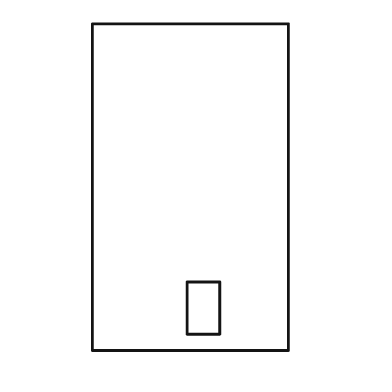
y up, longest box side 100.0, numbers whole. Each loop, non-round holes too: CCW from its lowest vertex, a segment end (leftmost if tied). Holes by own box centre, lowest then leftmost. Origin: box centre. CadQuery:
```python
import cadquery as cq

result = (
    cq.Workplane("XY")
    .moveTo(-30.0, -50.0)
    .lineTo(30.0, -50.0)
    .lineTo(30.0, 50.0)
    .lineTo(-30.0, 50.0)
    .close()
    .moveTo(-1.0, -45.0)
    .lineTo(9.0, -45.0)
    .lineTo(9.0, -29.0)
    .lineTo(-1.0, -29.0)
    .close()
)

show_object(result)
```